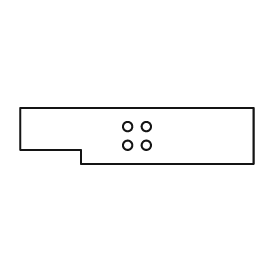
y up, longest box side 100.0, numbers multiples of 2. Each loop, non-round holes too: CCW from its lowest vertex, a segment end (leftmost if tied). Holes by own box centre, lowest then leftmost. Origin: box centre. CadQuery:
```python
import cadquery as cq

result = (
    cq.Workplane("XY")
    .moveTo(-24.0, -12.0)
    .lineTo(50.0, -12.0)
    .lineTo(50.0, 12.0)
    .lineTo(-50.0, 12.0)
    .lineTo(-50.0, -6.0)
    .lineTo(-24.0, -6.0)
    .close()
    .moveTo(-4.0, -4.0)
    .circle(2.0)
    .moveTo(4.0, -4.0)
    .circle(2.0)
    .moveTo(-4.0, 4.0)
    .circle(2.0)
    .moveTo(4.0, 4.0)
    .circle(2.0)
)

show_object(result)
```